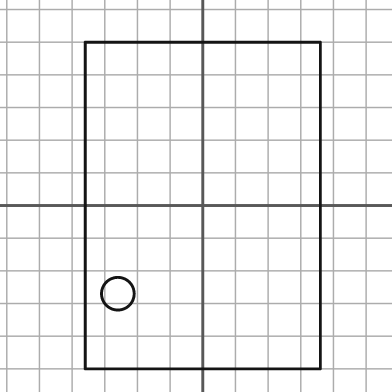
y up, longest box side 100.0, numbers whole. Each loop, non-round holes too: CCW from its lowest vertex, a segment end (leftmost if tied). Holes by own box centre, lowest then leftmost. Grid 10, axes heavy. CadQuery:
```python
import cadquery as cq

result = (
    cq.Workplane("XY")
    .moveTo(-36.0, -50.0)
    .lineTo(36.0, -50.0)
    .lineTo(36.0, 50.0)
    .lineTo(-36.0, 50.0)
    .close()
    .moveTo(-26.0, -27.0)
    .circle(5.0)
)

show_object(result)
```